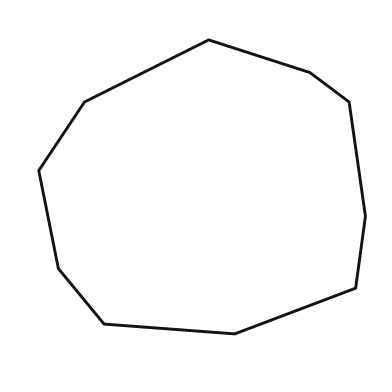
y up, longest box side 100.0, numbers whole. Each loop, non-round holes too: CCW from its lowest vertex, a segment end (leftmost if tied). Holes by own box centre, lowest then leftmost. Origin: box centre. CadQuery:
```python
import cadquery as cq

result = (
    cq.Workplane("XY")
    .moveTo(10.0, -45.0)
    .lineTo(47.0, -31.0)
    .lineTo(50.0, -9.0)
    .lineTo(45.0, 26.0)
    .lineTo(33.0, 35.0)
    .lineTo(2.0, 45.0)
    .lineTo(-36.0, 26.0)
    .lineTo(-50.0, 5.0)
    .lineTo(-44.0, -25.0)
    .lineTo(-30.0, -42.0)
    .close()
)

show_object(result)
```